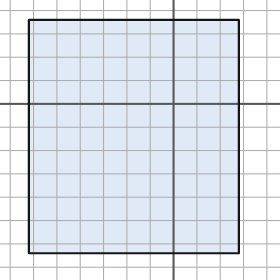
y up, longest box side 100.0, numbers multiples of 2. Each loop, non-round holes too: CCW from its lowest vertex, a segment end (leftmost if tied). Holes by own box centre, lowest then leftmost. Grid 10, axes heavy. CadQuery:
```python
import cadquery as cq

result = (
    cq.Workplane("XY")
    .moveTo(-62.0, -64.0)
    .lineTo(28.0, -64.0)
    .lineTo(28.0, 36.0)
    .lineTo(-62.0, 36.0)
    .close()
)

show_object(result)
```